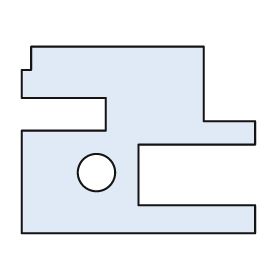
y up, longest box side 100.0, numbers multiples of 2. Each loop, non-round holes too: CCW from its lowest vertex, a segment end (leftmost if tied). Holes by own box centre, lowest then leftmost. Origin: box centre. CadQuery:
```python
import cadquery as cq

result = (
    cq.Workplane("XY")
    .moveTo(-50.0, -40.0)
    .lineTo(50.0, -40.0)
    .lineTo(50.0, -28.0)
    .lineTo(0.0, -28.0)
    .lineTo(0.0, -2.0)
    .lineTo(50.0, -2.0)
    .lineTo(50.0, 8.0)
    .lineTo(28.0, 8.0)
    .lineTo(28.0, 40.0)
    .lineTo(-46.0, 40.0)
    .lineTo(-46.0, 30.0)
    .lineTo(-50.0, 30.0)
    .lineTo(-50.0, 18.0)
    .lineTo(-14.0, 18.0)
    .lineTo(-14.0, 4.0)
    .lineTo(-50.0, 4.0)
    .close()
    .moveTo(-18.0, -14.0)
    .circle(8.0)
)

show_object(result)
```